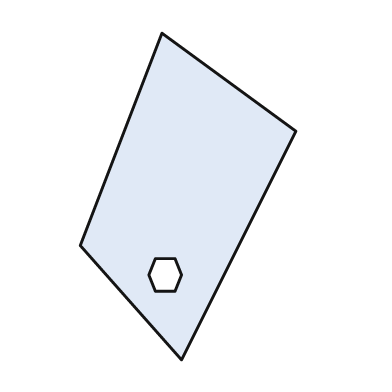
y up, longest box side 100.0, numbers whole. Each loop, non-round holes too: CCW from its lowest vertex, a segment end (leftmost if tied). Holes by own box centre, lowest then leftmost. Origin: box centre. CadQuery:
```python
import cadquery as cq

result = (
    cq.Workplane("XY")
    .moveTo(-2.0, -50.0)
    .lineTo(33.0, 20.0)
    .lineTo(-8.0, 50.0)
    .lineTo(-33.0, -15.0)
    .close()
    .moveTo(-10.0, -29.0)
    .lineTo(-4.0, -29.0)
    .lineTo(-2.0, -24.0)
    .lineTo(-4.0, -19.0)
    .lineTo(-10.0, -19.0)
    .lineTo(-12.0, -24.0)
    .close()
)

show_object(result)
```